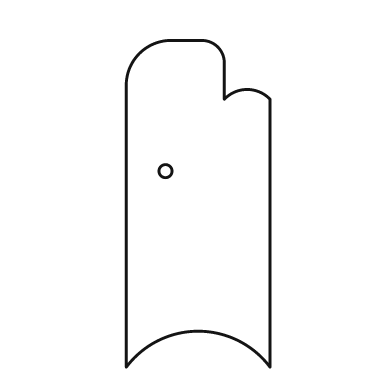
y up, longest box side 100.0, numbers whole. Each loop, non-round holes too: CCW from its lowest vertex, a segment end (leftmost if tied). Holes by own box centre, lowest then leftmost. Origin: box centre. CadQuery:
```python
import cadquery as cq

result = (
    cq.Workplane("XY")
    .moveTo(-22.0, -50.0)
    .threePointArc((0.0, -39.0), (22.0, -50.0))
    .lineTo(22.0, 32.0)
    .threePointArc((15.0, 35.0), (8.0, 32.0))
    .lineTo(8.0, 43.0)
    .threePointArc((6.0, 48.0), (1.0, 50.0))
    .lineTo(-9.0, 50.0)
    .threePointArc((-18.0, 46.0), (-22.0, 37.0))
    .close()
    .moveTo(-10.0, 10.0)
    .circle(2.0)
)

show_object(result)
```